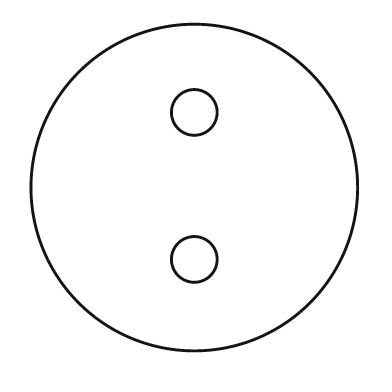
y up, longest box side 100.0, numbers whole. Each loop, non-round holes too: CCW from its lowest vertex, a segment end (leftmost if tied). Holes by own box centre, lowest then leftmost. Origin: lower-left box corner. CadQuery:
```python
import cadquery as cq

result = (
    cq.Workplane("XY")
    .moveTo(50.0, 50.0)
    .circle(50.0)
    .moveTo(50.0, 28.0)
    .circle(7.0)
    .moveTo(50.0, 73.0)
    .circle(7.0)
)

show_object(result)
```